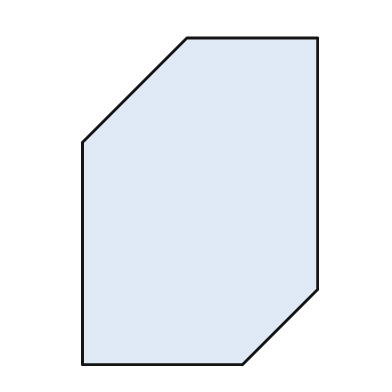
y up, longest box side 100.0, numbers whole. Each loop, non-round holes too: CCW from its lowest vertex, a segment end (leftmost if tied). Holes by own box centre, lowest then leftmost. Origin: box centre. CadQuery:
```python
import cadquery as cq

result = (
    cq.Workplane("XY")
    .moveTo(-36.0, -50.0)
    .lineTo(13.0, -50.0)
    .lineTo(36.0, -27.0)
    .lineTo(36.0, 50.0)
    .lineTo(-4.0, 50.0)
    .lineTo(-36.0, 18.0)
    .close()
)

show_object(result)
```